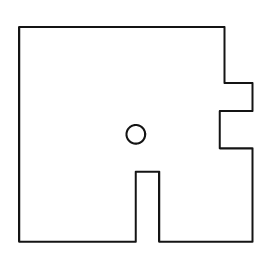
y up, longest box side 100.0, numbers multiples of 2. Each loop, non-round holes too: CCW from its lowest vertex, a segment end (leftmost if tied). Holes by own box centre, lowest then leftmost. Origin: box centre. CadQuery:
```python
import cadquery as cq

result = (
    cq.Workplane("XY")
    .moveTo(-50.0, -46.0)
    .lineTo(0.0, -46.0)
    .lineTo(0.0, -16.0)
    .lineTo(10.0, -16.0)
    .lineTo(10.0, -46.0)
    .lineTo(50.0, -46.0)
    .lineTo(50.0, -6.0)
    .lineTo(36.0, -6.0)
    .lineTo(36.0, 10.0)
    .lineTo(50.0, 10.0)
    .lineTo(50.0, 22.0)
    .lineTo(38.0, 22.0)
    .lineTo(38.0, 46.0)
    .lineTo(-50.0, 46.0)
    .close()
    .moveTo(0.0, 0.0)
    .circle(4.0)
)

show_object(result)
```